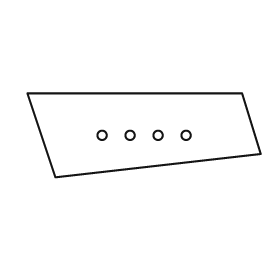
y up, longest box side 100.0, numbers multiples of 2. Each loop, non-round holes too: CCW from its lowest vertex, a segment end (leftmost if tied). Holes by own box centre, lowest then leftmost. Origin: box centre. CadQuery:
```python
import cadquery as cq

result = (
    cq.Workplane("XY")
    .moveTo(-38.0, -18.0)
    .lineTo(50.0, -8.0)
    .lineTo(42.0, 18.0)
    .lineTo(-50.0, 18.0)
    .close()
    .moveTo(-18.0, 0.0)
    .circle(2.0)
    .moveTo(-6.0, 0.0)
    .circle(2.0)
    .moveTo(6.0, 0.0)
    .circle(2.0)
    .moveTo(18.0, 0.0)
    .circle(2.0)
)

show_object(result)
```